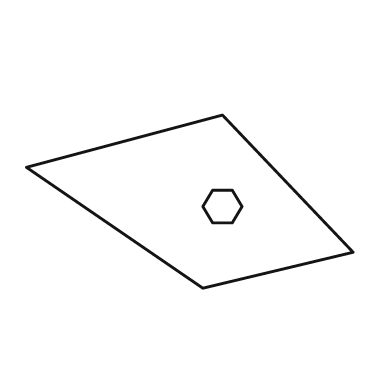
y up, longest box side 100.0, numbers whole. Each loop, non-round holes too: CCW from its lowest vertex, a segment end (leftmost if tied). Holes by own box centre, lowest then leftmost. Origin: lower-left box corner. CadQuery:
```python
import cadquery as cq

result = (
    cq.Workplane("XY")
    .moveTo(54.0, 0.0)
    .lineTo(100.0, 11.0)
    .lineTo(60.0, 53.0)
    .lineTo(0.0, 37.0)
    .close()
    .moveTo(57.0, 20.0)
    .lineTo(63.0, 20.0)
    .lineTo(66.0, 25.0)
    .lineTo(63.0, 30.0)
    .lineTo(57.0, 30.0)
    .lineTo(54.0, 25.0)
    .close()
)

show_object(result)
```